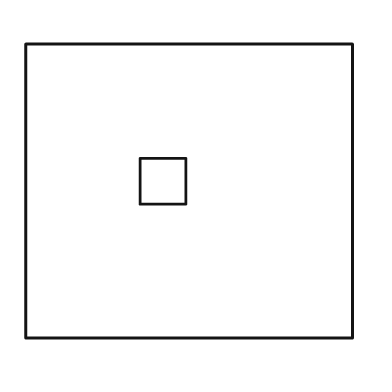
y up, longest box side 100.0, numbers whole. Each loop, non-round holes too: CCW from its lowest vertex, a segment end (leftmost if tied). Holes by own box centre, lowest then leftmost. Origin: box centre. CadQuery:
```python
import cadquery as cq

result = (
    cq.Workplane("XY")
    .moveTo(-50.0, -45.0)
    .lineTo(50.0, -45.0)
    .lineTo(50.0, 45.0)
    .lineTo(-50.0, 45.0)
    .close()
    .moveTo(-15.0, -4.0)
    .lineTo(-1.0, -4.0)
    .lineTo(-1.0, 10.0)
    .lineTo(-15.0, 10.0)
    .close()
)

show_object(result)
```